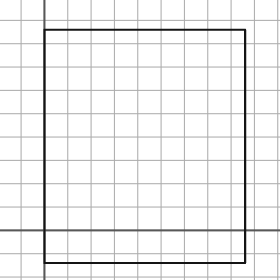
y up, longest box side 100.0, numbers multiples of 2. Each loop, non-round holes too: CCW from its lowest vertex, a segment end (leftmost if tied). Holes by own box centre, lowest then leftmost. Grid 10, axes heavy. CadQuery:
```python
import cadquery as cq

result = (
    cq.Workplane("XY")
    .moveTo(0.0, -14.0)
    .lineTo(86.0, -14.0)
    .lineTo(86.0, 86.0)
    .lineTo(0.0, 86.0)
    .close()
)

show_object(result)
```